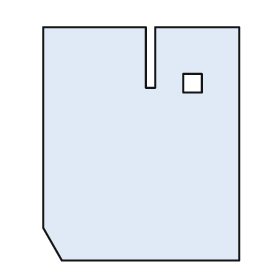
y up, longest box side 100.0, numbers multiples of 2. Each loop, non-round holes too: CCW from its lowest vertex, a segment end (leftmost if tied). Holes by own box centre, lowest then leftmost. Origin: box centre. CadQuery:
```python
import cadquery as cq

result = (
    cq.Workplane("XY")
    .moveTo(-34.0, -50.0)
    .lineTo(42.0, -50.0)
    .lineTo(42.0, 50.0)
    .lineTo(6.0, 50.0)
    .lineTo(6.0, 24.0)
    .lineTo(2.0, 24.0)
    .lineTo(2.0, 50.0)
    .lineTo(-42.0, 50.0)
    .lineTo(-42.0, -36.0)
    .close()
    .moveTo(18.0, 22.0)
    .lineTo(26.0, 22.0)
    .lineTo(26.0, 30.0)
    .lineTo(18.0, 30.0)
    .close()
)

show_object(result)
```